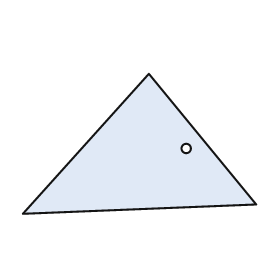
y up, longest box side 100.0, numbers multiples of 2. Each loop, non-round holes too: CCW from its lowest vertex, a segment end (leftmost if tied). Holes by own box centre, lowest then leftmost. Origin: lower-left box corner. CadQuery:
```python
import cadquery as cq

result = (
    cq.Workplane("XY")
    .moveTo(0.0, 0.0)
    .lineTo(100.0, 4.0)
    .lineTo(54.0, 60.0)
    .close()
    .moveTo(70.0, 28.0)
    .circle(2.0)
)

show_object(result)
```